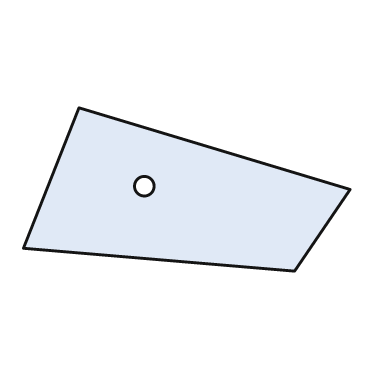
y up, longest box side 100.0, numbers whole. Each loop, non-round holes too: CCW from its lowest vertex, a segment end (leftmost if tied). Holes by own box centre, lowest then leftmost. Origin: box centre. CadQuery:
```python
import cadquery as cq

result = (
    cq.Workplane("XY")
    .moveTo(33.0, -25.0)
    .lineTo(50.0, 0.0)
    .lineTo(-33.0, 25.0)
    .lineTo(-50.0, -18.0)
    .close()
    .moveTo(-13.0, 1.0)
    .circle(3.0)
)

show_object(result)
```